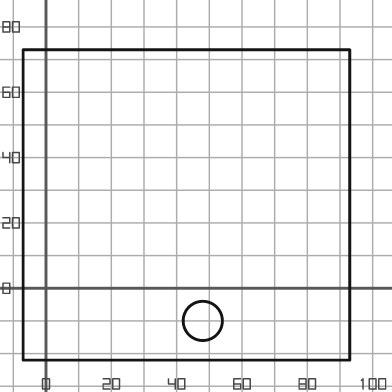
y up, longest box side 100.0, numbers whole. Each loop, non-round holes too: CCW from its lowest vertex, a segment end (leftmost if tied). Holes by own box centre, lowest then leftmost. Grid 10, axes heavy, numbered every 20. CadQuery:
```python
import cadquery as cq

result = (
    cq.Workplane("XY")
    .moveTo(-7.0, -22.0)
    .lineTo(93.0, -22.0)
    .lineTo(93.0, 73.0)
    .lineTo(-7.0, 73.0)
    .close()
    .moveTo(48.0, -10.0)
    .circle(6.0)
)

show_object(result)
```